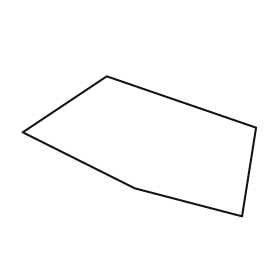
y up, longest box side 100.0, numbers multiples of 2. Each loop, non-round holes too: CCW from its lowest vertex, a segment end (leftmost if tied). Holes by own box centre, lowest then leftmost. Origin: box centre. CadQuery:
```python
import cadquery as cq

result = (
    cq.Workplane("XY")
    .moveTo(44.0, -30.0)
    .lineTo(50.0, 8.0)
    .lineTo(-14.0, 30.0)
    .lineTo(-50.0, 6.0)
    .lineTo(-2.0, -18.0)
    .close()
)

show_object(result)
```